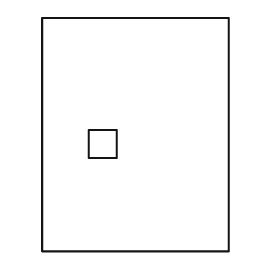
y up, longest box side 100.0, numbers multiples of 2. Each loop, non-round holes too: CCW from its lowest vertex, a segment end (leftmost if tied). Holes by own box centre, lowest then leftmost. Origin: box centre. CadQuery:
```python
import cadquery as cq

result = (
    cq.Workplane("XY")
    .moveTo(-40.0, -50.0)
    .lineTo(40.0, -50.0)
    .lineTo(40.0, 50.0)
    .lineTo(-40.0, 50.0)
    .close()
    .moveTo(-20.0, -10.0)
    .lineTo(-8.0, -10.0)
    .lineTo(-8.0, 2.0)
    .lineTo(-20.0, 2.0)
    .close()
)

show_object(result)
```